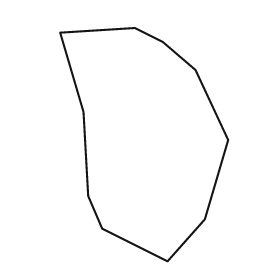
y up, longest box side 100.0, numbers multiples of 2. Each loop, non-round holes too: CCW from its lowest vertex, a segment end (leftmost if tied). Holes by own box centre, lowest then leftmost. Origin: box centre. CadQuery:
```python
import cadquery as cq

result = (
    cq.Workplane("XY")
    .moveTo(10.0, -50.0)
    .lineTo(26.0, -32.0)
    .lineTo(36.0, 2.0)
    .lineTo(22.0, 32.0)
    .lineTo(8.0, 44.0)
    .lineTo(-4.0, 50.0)
    .lineTo(-36.0, 48.0)
    .lineTo(-26.0, 14.0)
    .lineTo(-24.0, -22.0)
    .lineTo(-18.0, -36.0)
    .close()
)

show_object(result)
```